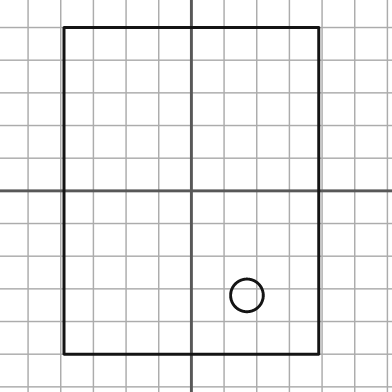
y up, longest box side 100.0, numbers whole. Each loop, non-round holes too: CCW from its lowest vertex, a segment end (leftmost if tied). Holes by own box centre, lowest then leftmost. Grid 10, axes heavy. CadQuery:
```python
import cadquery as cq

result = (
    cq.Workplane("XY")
    .moveTo(-39.0, -50.0)
    .lineTo(39.0, -50.0)
    .lineTo(39.0, 50.0)
    .lineTo(-39.0, 50.0)
    .close()
    .moveTo(17.0, -32.0)
    .circle(5.0)
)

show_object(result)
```